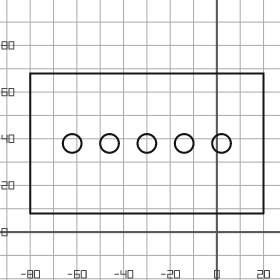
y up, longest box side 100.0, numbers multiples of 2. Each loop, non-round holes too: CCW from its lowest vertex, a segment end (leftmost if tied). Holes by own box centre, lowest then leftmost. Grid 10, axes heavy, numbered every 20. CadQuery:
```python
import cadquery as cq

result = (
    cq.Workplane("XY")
    .moveTo(-80.0, 8.0)
    .lineTo(20.0, 8.0)
    .lineTo(20.0, 68.0)
    .lineTo(-80.0, 68.0)
    .close()
    .moveTo(-62.0, 38.0)
    .circle(4.0)
    .moveTo(-46.0, 38.0)
    .circle(4.0)
    .moveTo(-30.0, 38.0)
    .circle(4.0)
    .moveTo(-14.0, 38.0)
    .circle(4.0)
    .moveTo(2.0, 38.0)
    .circle(4.0)
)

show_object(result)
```